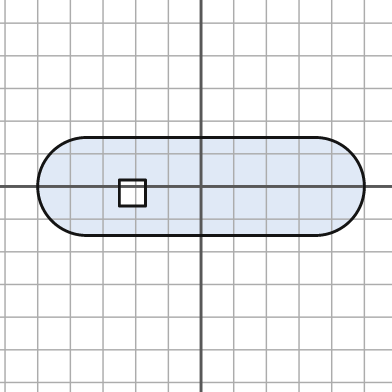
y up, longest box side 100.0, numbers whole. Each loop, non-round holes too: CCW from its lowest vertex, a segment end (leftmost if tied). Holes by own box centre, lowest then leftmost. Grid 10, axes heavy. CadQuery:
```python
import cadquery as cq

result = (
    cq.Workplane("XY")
    .moveTo(-35.0, -15.0)
    .lineTo(35.0, -15.0)
    .threePointArc((50.0, 0.0), (35.0, 15.0))
    .lineTo(-35.0, 15.0)
    .threePointArc((-50.0, 0.0), (-35.0, -15.0))
    .close()
    .moveTo(-25.0, -6.0)
    .lineTo(-17.0, -6.0)
    .lineTo(-17.0, 2.0)
    .lineTo(-25.0, 2.0)
    .close()
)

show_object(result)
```